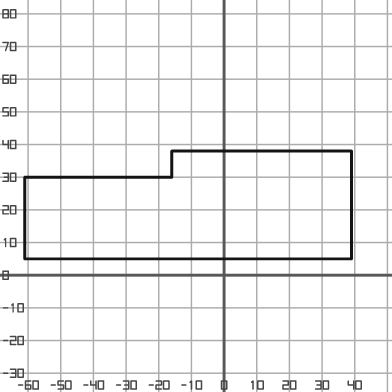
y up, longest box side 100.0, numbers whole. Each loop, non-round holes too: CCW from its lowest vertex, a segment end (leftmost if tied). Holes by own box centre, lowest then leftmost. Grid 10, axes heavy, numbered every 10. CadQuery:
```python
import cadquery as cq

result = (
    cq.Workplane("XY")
    .moveTo(-61.0, 5.0)
    .lineTo(39.0, 5.0)
    .lineTo(39.0, 38.0)
    .lineTo(-16.0, 38.0)
    .lineTo(-16.0, 30.0)
    .lineTo(-61.0, 30.0)
    .close()
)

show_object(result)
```